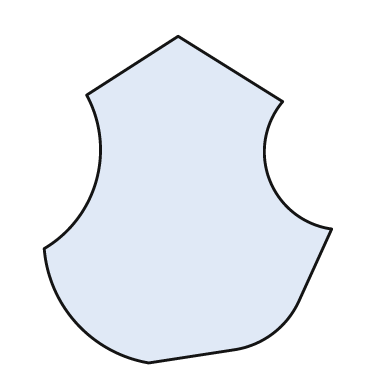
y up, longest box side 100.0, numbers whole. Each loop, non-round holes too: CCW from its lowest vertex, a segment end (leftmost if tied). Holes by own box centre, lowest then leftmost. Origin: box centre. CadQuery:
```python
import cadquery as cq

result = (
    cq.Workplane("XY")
    .moveTo(-12.0, -50.0)
    .lineTo(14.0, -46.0)
    .threePointArc((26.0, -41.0), (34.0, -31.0))
    .lineTo(44.0, -9.0)
    .threePointArc((25.0, 6.0), (29.0, 30.0))
    .lineTo(-3.0, 50.0)
    .lineTo(-31.0, 32.0)
    .threePointArc((-28.0, 6.0), (-44.0, -15.0))
    .threePointArc((-34.0, -38.0), (-12.0, -50.0))
    .close()
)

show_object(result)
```